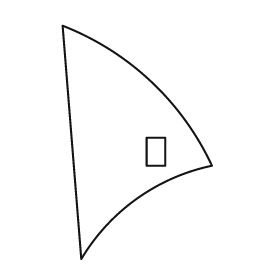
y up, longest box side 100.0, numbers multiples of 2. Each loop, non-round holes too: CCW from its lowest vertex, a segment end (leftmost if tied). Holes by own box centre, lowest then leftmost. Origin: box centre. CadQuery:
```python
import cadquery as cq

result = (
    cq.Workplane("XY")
    .moveTo(-24.0, -50.0)
    .threePointArc((0.0, -24.0), (32.0, -10.0))
    .threePointArc((6.0, 26.0), (-32.0, 50.0))
    .close()
    .moveTo(4.0, -10.0)
    .lineTo(12.0, -10.0)
    .lineTo(12.0, 2.0)
    .lineTo(4.0, 2.0)
    .close()
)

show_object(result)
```